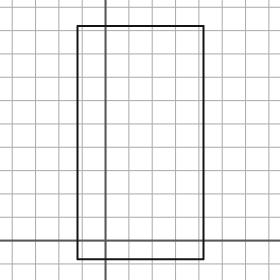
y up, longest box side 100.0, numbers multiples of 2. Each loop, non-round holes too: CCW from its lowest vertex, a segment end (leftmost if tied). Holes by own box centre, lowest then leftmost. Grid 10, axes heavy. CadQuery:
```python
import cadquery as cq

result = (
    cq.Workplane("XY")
    .moveTo(-12.0, -8.0)
    .lineTo(42.0, -8.0)
    .lineTo(42.0, 92.0)
    .lineTo(-12.0, 92.0)
    .close()
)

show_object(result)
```